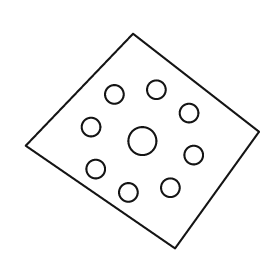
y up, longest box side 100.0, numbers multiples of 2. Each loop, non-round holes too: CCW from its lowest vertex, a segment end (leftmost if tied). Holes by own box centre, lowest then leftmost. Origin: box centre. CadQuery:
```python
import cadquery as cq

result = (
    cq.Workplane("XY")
    .moveTo(14.0, -46.0)
    .lineTo(50.0, 4.0)
    .lineTo(-4.0, 46.0)
    .lineTo(-50.0, -2.0)
    .close()
    .moveTo(-6.0, -22.0)
    .circle(4.0)
    .moveTo(12.0, -20.0)
    .circle(4.0)
    .moveTo(-20.0, -12.0)
    .circle(4.0)
    .moveTo(22.0, -6.0)
    .circle(4.0)
    .moveTo(0.0, 0.0)
    .circle(6.0)
    .moveTo(-22.0, 6.0)
    .circle(4.0)
    .moveTo(20.0, 12.0)
    .circle(4.0)
    .moveTo(-12.0, 20.0)
    .circle(4.0)
    .moveTo(6.0, 22.0)
    .circle(4.0)
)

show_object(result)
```